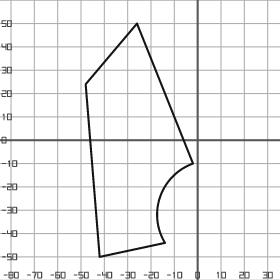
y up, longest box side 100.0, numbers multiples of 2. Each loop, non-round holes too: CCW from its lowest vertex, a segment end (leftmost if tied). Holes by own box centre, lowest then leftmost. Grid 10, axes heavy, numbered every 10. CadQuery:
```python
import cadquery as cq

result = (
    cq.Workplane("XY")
    .moveTo(-42.0, -50.0)
    .lineTo(-14.0, -44.0)
    .threePointArc((-16.0, -24.0), (-2.0, -10.0))
    .lineTo(-26.0, 50.0)
    .lineTo(-48.0, 24.0)
    .close()
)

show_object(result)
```